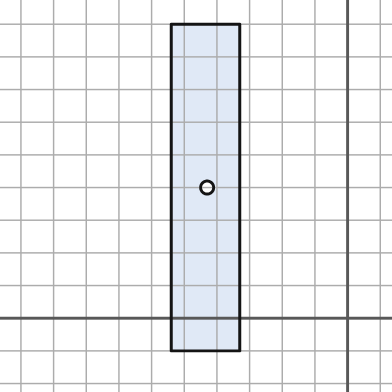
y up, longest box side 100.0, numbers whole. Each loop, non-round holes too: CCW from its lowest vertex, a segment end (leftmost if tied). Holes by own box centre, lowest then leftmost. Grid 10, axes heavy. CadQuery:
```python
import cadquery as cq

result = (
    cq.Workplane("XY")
    .moveTo(-54.0, -10.0)
    .lineTo(-33.0, -10.0)
    .lineTo(-33.0, 90.0)
    .lineTo(-54.0, 90.0)
    .close()
    .moveTo(-43.0, 40.0)
    .circle(2.0)
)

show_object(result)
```